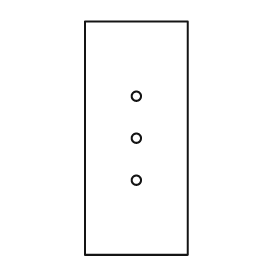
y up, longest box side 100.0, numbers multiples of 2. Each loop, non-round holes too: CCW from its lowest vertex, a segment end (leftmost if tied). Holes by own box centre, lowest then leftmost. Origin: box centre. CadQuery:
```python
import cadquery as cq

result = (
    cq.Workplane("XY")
    .moveTo(-22.0, -50.0)
    .lineTo(22.0, -50.0)
    .lineTo(22.0, 50.0)
    .lineTo(-22.0, 50.0)
    .close()
    .moveTo(0.0, -18.0)
    .circle(2.0)
    .moveTo(0.0, 0.0)
    .circle(2.0)
    .moveTo(0.0, 18.0)
    .circle(2.0)
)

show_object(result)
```